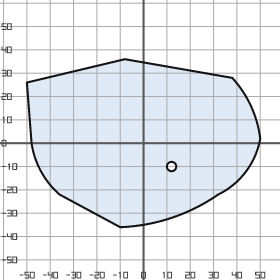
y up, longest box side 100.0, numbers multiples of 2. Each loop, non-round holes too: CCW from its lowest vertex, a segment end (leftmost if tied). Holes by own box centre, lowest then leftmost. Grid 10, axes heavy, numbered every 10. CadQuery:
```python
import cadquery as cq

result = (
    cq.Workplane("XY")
    .moveTo(-10.0, -36.0)
    .threePointArc((12.0, -32.0), (32.0, -22.0))
    .threePointArc((44.0, -12.0), (50.0, 2.0))
    .threePointArc((46.0, 16.0), (38.0, 28.0))
    .lineTo(-8.0, 36.0)
    .lineTo(-50.0, 26.0)
    .lineTo(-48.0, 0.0)
    .threePointArc((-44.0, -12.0), (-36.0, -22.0))
    .close()
    .moveTo(12.0, -10.0)
    .circle(2.0)
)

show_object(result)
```